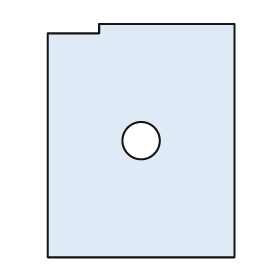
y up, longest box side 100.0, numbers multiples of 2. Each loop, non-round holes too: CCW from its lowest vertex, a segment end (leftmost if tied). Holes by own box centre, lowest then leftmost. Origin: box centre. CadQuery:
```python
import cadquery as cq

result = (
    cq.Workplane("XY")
    .moveTo(-40.0, -50.0)
    .lineTo(40.0, -50.0)
    .lineTo(40.0, 50.0)
    .lineTo(-18.0, 50.0)
    .lineTo(-18.0, 46.0)
    .lineTo(-40.0, 46.0)
    .close()
    .moveTo(0.0, 0.0)
    .circle(8.0)
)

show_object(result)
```